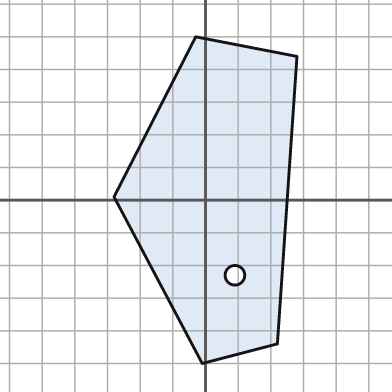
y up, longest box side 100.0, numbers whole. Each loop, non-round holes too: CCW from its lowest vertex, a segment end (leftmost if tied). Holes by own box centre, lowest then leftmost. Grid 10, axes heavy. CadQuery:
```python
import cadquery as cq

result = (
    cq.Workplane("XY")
    .moveTo(-1.0, -50.0)
    .lineTo(22.0, -44.0)
    .lineTo(28.0, 44.0)
    .lineTo(-3.0, 50.0)
    .lineTo(-28.0, 1.0)
    .close()
    .moveTo(9.0, -23.0)
    .circle(3.0)
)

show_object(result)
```